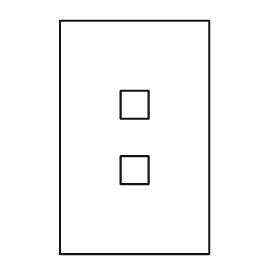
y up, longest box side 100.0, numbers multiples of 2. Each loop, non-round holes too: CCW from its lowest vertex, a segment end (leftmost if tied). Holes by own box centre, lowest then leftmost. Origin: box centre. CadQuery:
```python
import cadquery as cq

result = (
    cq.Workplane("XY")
    .moveTo(-32.0, -50.0)
    .lineTo(32.0, -50.0)
    .lineTo(32.0, 50.0)
    .lineTo(-32.0, 50.0)
    .close()
    .moveTo(-6.0, -20.0)
    .lineTo(6.0, -20.0)
    .lineTo(6.0, -8.0)
    .lineTo(-6.0, -8.0)
    .close()
    .moveTo(-6.0, 8.0)
    .lineTo(6.0, 8.0)
    .lineTo(6.0, 20.0)
    .lineTo(-6.0, 20.0)
    .close()
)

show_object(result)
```